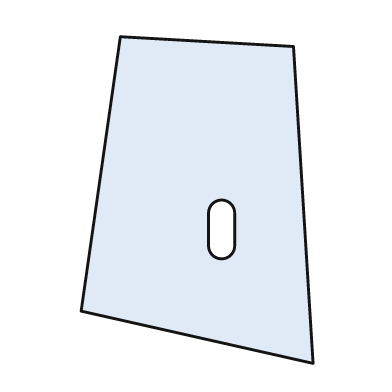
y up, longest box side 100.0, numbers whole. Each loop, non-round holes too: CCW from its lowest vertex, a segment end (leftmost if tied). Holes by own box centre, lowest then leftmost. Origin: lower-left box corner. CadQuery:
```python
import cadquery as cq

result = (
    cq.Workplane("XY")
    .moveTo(71.0, 0.0)
    .lineTo(65.0, 97.0)
    .lineTo(12.0, 100.0)
    .lineTo(0.0, 16.0)
    .close()
    .moveTo(39.0, 36.0)
    .threePointArc((43.0, 32.0), (47.0, 36.0))
    .lineTo(47.0, 46.0)
    .threePointArc((43.0, 50.0), (39.0, 46.0))
    .close()
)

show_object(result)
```